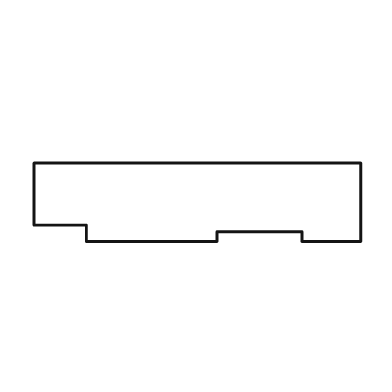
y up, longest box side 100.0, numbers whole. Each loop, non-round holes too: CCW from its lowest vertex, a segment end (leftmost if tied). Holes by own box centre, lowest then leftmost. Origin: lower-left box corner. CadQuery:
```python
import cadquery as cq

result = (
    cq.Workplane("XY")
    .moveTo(16.0, 0.0)
    .lineTo(56.0, 0.0)
    .lineTo(56.0, 3.0)
    .lineTo(82.0, 3.0)
    .lineTo(82.0, 0.0)
    .lineTo(100.0, 0.0)
    .lineTo(100.0, 24.0)
    .lineTo(0.0, 24.0)
    .lineTo(0.0, 5.0)
    .lineTo(16.0, 5.0)
    .close()
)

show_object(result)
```